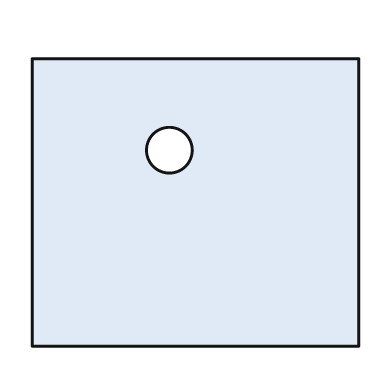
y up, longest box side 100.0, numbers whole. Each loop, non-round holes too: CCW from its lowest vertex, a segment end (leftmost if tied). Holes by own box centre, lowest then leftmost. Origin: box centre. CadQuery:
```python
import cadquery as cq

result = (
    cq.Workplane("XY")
    .moveTo(-50.0, -44.0)
    .lineTo(50.0, -44.0)
    .lineTo(50.0, 44.0)
    .lineTo(-50.0, 44.0)
    .close()
    .moveTo(-8.0, 16.0)
    .circle(7.0)
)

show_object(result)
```